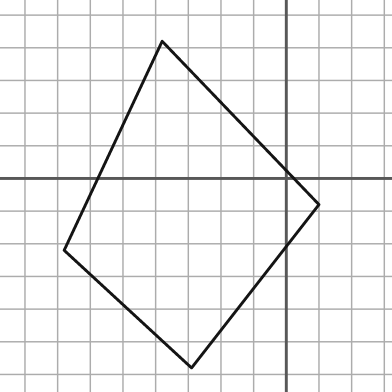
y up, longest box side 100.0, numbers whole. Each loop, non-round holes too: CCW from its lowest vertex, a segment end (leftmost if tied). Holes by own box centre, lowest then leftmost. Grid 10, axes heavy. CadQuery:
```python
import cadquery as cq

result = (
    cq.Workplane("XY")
    .moveTo(-29.0, -58.0)
    .lineTo(10.0, -8.0)
    .lineTo(-38.0, 42.0)
    .lineTo(-68.0, -22.0)
    .close()
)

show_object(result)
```